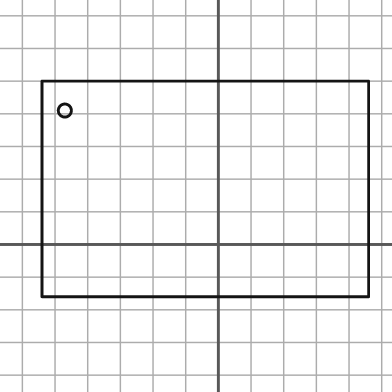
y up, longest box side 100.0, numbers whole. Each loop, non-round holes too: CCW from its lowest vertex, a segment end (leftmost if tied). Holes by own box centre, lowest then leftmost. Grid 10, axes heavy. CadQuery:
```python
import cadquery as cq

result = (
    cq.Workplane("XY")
    .moveTo(-54.0, -16.0)
    .lineTo(46.0, -16.0)
    .lineTo(46.0, 50.0)
    .lineTo(-54.0, 50.0)
    .close()
    .moveTo(-47.0, 41.0)
    .circle(2.0)
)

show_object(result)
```